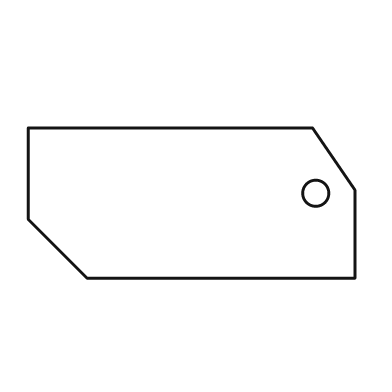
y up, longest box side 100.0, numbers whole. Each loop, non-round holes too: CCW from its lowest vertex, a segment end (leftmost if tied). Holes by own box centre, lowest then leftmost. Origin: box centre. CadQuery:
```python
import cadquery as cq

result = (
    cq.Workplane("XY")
    .moveTo(-32.0, -23.0)
    .lineTo(50.0, -23.0)
    .lineTo(50.0, 4.0)
    .lineTo(37.0, 23.0)
    .lineTo(-50.0, 23.0)
    .lineTo(-50.0, -5.0)
    .close()
    .moveTo(38.0, 3.0)
    .circle(4.0)
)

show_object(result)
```